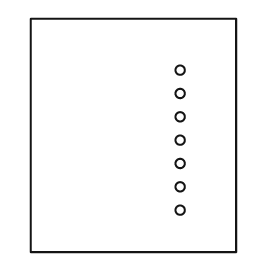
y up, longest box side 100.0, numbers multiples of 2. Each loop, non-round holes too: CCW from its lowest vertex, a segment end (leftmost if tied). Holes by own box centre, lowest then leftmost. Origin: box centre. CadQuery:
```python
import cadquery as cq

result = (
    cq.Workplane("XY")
    .moveTo(-44.0, -50.0)
    .lineTo(44.0, -50.0)
    .lineTo(44.0, 50.0)
    .lineTo(-44.0, 50.0)
    .close()
    .moveTo(20.0, -32.0)
    .circle(2.0)
    .moveTo(20.0, -22.0)
    .circle(2.0)
    .moveTo(20.0, -12.0)
    .circle(2.0)
    .moveTo(20.0, -2.0)
    .circle(2.0)
    .moveTo(20.0, 8.0)
    .circle(2.0)
    .moveTo(20.0, 18.0)
    .circle(2.0)
    .moveTo(20.0, 28.0)
    .circle(2.0)
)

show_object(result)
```